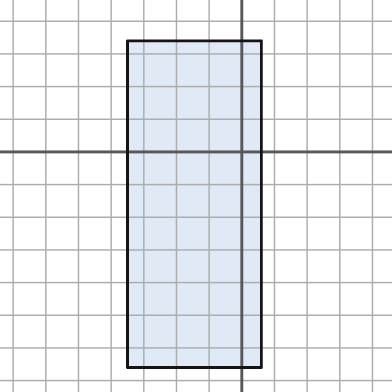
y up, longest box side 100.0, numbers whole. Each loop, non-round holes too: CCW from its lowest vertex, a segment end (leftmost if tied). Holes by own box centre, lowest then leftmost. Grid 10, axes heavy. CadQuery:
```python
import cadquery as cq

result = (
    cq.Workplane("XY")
    .moveTo(-35.0, -66.0)
    .lineTo(6.0, -66.0)
    .lineTo(6.0, 34.0)
    .lineTo(-35.0, 34.0)
    .close()
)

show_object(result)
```